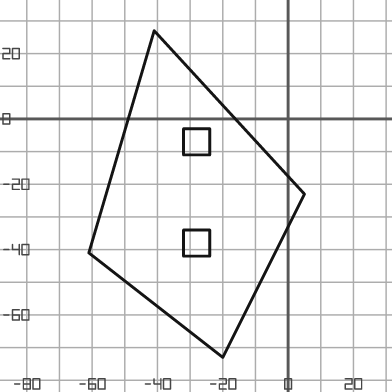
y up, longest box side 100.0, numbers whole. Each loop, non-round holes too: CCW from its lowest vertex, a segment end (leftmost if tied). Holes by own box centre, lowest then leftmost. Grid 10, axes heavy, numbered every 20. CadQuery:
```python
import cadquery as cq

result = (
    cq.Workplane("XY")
    .moveTo(-20.0, -73.0)
    .lineTo(5.0, -23.0)
    .lineTo(-41.0, 27.0)
    .lineTo(-61.0, -41.0)
    .close()
    .moveTo(-32.0, -42.0)
    .lineTo(-24.0, -42.0)
    .lineTo(-24.0, -34.0)
    .lineTo(-32.0, -34.0)
    .close()
    .moveTo(-32.0, -11.0)
    .lineTo(-24.0, -11.0)
    .lineTo(-24.0, -3.0)
    .lineTo(-32.0, -3.0)
    .close()
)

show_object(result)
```